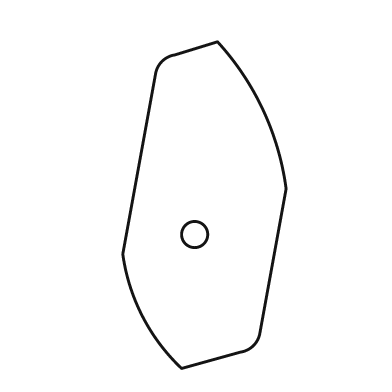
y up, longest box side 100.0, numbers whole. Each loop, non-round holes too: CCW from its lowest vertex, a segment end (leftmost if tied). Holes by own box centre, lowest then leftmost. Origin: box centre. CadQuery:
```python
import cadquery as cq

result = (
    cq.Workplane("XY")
    .moveTo(-7.0, -50.0)
    .lineTo(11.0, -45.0)
    .threePointArc((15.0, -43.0), (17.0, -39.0))
    .lineTo(25.0, 5.0)
    .threePointArc((18.0, 29.0), (4.0, 50.0))
    .lineTo(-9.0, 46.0)
    .threePointArc((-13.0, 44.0), (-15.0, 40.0))
    .lineTo(-25.0, -15.0)
    .threePointArc((-19.0, -34.0), (-7.0, -50.0))
    .close()
    .moveTo(-3.0, -9.0)
    .circle(4.0)
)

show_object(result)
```